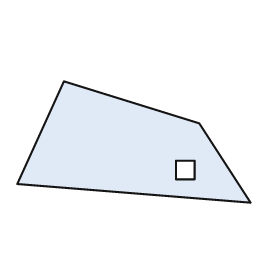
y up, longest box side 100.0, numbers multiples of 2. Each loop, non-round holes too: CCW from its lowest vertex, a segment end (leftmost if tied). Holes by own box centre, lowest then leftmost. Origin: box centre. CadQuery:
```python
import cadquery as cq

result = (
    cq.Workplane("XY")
    .moveTo(50.0, -26.0)
    .lineTo(28.0, 8.0)
    .lineTo(-30.0, 26.0)
    .lineTo(-50.0, -18.0)
    .close()
    .moveTo(18.0, -16.0)
    .lineTo(26.0, -16.0)
    .lineTo(26.0, -8.0)
    .lineTo(18.0, -8.0)
    .close()
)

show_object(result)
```